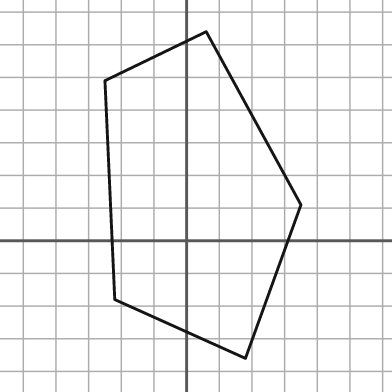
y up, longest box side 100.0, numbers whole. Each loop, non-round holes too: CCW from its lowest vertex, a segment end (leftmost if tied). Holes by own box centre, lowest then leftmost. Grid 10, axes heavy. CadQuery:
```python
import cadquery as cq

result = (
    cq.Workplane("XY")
    .moveTo(18.0, -36.0)
    .lineTo(35.0, 11.0)
    .lineTo(6.0, 64.0)
    .lineTo(-25.0, 49.0)
    .lineTo(-22.0, -18.0)
    .close()
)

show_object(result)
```